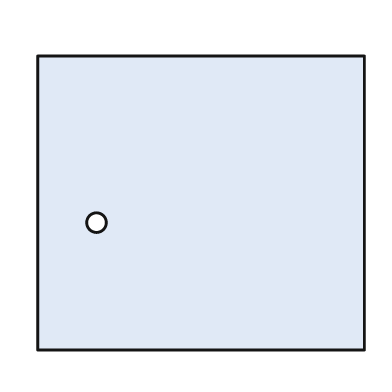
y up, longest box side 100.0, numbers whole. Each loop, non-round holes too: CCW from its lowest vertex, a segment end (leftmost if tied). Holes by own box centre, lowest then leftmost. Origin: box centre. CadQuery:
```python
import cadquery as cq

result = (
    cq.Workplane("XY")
    .moveTo(-50.0, -45.0)
    .lineTo(50.0, -45.0)
    .lineTo(50.0, 45.0)
    .lineTo(-50.0, 45.0)
    .close()
    .moveTo(-32.0, -6.0)
    .circle(3.0)
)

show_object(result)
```